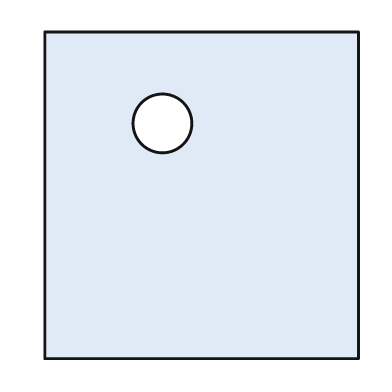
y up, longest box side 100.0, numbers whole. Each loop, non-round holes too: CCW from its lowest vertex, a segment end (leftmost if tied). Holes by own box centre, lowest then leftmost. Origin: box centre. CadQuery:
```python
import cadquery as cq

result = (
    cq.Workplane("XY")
    .moveTo(-48.0, -50.0)
    .lineTo(48.0, -50.0)
    .lineTo(48.0, 50.0)
    .lineTo(-48.0, 50.0)
    .close()
    .moveTo(-12.0, 22.0)
    .circle(9.0)
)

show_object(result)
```